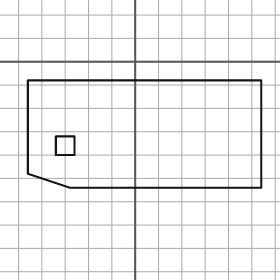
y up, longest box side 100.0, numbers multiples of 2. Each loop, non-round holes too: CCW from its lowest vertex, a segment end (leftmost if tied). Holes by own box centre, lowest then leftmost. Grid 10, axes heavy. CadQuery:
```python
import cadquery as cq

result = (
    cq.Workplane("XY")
    .moveTo(-28.0, -54.0)
    .lineTo(54.0, -54.0)
    .lineTo(54.0, -8.0)
    .lineTo(-46.0, -8.0)
    .lineTo(-46.0, -48.0)
    .close()
    .moveTo(-34.0, -40.0)
    .lineTo(-26.0, -40.0)
    .lineTo(-26.0, -32.0)
    .lineTo(-34.0, -32.0)
    .close()
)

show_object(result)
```